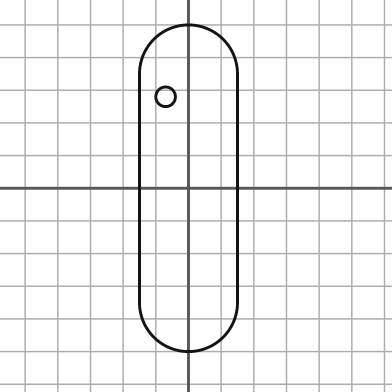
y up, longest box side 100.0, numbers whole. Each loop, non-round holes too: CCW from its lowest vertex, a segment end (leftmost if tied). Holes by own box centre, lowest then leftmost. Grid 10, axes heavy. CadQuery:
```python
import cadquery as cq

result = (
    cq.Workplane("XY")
    .moveTo(-15.0, -35.0)
    .threePointArc((0.0, -50.0), (15.0, -35.0))
    .lineTo(15.0, 35.0)
    .threePointArc((0.0, 50.0), (-15.0, 35.0))
    .close()
    .moveTo(-7.0, 28.0)
    .circle(3.0)
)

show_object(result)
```